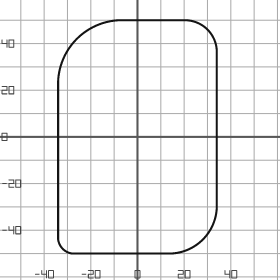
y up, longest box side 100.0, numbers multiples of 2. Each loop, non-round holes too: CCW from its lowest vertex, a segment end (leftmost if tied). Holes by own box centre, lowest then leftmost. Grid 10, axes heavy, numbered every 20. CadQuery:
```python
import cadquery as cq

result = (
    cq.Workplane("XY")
    .moveTo(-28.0, -50.0)
    .lineTo(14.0, -50.0)
    .threePointArc((28.0, -44.0), (34.0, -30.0))
    .lineTo(34.0, 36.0)
    .threePointArc((30.0, 46.0), (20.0, 50.0))
    .lineTo(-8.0, 50.0)
    .threePointArc((-26.0, 42.0), (-34.0, 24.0))
    .lineTo(-34.0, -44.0)
    .threePointArc((-32.0, -48.0), (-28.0, -50.0))
    .close()
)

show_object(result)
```